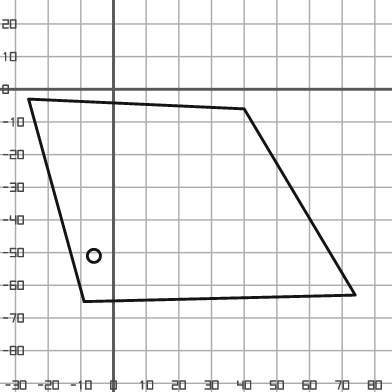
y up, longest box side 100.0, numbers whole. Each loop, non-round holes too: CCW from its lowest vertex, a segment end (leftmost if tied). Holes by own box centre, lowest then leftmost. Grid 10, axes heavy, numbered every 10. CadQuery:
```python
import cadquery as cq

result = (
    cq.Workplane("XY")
    .moveTo(-9.0, -65.0)
    .lineTo(74.0, -63.0)
    .lineTo(40.0, -6.0)
    .lineTo(-26.0, -3.0)
    .close()
    .moveTo(-6.0, -51.0)
    .circle(2.0)
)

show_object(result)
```